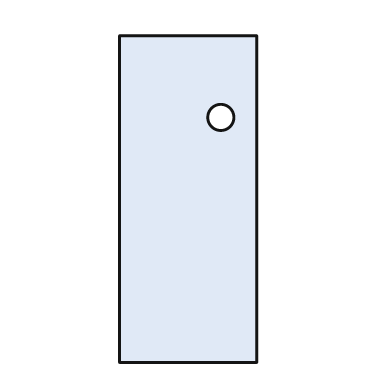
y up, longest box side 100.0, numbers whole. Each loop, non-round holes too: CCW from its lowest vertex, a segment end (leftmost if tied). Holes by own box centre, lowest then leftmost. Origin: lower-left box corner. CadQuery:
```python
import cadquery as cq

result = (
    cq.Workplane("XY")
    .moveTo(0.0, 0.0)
    .lineTo(42.0, 0.0)
    .lineTo(42.0, 100.0)
    .lineTo(0.0, 100.0)
    .close()
    .moveTo(31.0, 75.0)
    .circle(4.0)
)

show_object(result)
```